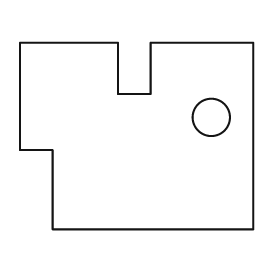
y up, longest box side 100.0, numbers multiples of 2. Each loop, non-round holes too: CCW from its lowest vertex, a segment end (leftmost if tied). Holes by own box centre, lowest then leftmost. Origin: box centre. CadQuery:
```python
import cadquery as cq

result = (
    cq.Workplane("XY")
    .moveTo(-36.0, -40.0)
    .lineTo(50.0, -40.0)
    .lineTo(50.0, 40.0)
    .lineTo(6.0, 40.0)
    .lineTo(6.0, 18.0)
    .lineTo(-8.0, 18.0)
    .lineTo(-8.0, 40.0)
    .lineTo(-50.0, 40.0)
    .lineTo(-50.0, -6.0)
    .lineTo(-36.0, -6.0)
    .close()
    .moveTo(32.0, 8.0)
    .circle(8.0)
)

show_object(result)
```